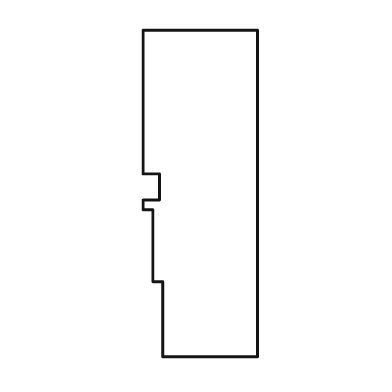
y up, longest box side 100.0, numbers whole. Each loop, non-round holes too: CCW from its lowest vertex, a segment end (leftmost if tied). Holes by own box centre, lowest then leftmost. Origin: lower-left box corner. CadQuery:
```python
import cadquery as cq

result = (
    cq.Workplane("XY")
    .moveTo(6.0, 0.0)
    .lineTo(35.0, 0.0)
    .lineTo(35.0, 100.0)
    .lineTo(0.0, 100.0)
    .lineTo(0.0, 56.0)
    .lineTo(5.0, 56.0)
    .lineTo(5.0, 48.0)
    .lineTo(0.0, 48.0)
    .lineTo(0.0, 45.0)
    .lineTo(3.0, 45.0)
    .lineTo(3.0, 23.0)
    .lineTo(6.0, 23.0)
    .close()
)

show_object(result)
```